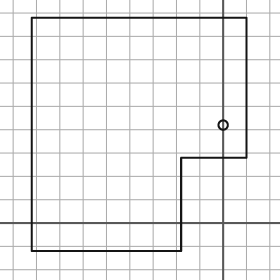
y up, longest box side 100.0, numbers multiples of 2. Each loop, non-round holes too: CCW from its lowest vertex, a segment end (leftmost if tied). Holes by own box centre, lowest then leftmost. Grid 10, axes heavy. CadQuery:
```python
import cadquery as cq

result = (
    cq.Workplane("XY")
    .moveTo(-82.0, -12.0)
    .lineTo(-18.0, -12.0)
    .lineTo(-18.0, 28.0)
    .lineTo(10.0, 28.0)
    .lineTo(10.0, 88.0)
    .lineTo(-82.0, 88.0)
    .close()
    .moveTo(0.0, 42.0)
    .circle(2.0)
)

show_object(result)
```